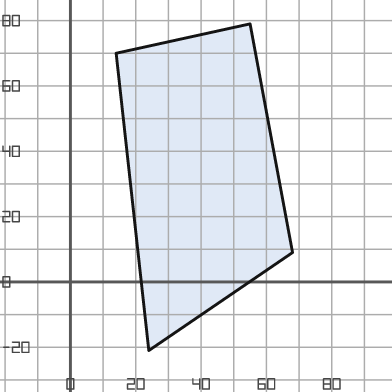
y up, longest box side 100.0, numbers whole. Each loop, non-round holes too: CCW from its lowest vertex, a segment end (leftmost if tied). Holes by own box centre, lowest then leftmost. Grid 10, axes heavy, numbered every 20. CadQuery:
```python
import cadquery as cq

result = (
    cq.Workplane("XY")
    .moveTo(24.0, -21.0)
    .lineTo(68.0, 9.0)
    .lineTo(55.0, 79.0)
    .lineTo(14.0, 70.0)
    .close()
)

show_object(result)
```